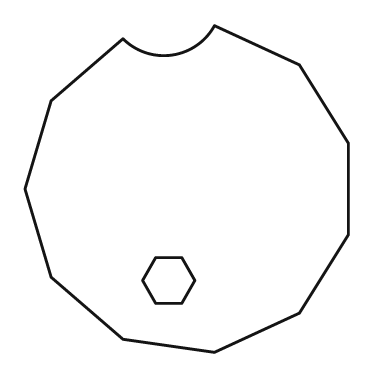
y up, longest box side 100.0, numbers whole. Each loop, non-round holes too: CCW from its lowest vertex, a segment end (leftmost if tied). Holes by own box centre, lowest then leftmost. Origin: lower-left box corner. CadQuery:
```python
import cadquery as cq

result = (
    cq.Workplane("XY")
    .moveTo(58.0, 0.0)
    .lineTo(84.0, 12.0)
    .lineTo(99.0, 36.0)
    .lineTo(99.0, 64.0)
    .lineTo(84.0, 88.0)
    .lineTo(58.0, 100.0)
    .threePointArc((45.0, 91.0), (30.0, 96.0))
    .lineTo(8.0, 77.0)
    .lineTo(0.0, 50.0)
    .lineTo(8.0, 23.0)
    .lineTo(30.0, 4.0)
    .close()
    .moveTo(40.0, 15.0)
    .lineTo(48.0, 15.0)
    .lineTo(52.0, 22.0)
    .lineTo(48.0, 29.0)
    .lineTo(40.0, 29.0)
    .lineTo(36.0, 22.0)
    .close()
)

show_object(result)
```